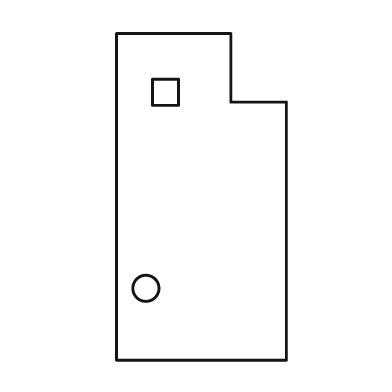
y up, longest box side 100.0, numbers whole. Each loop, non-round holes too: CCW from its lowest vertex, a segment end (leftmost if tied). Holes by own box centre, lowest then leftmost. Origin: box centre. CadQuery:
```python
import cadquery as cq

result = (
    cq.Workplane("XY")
    .moveTo(-26.0, -50.0)
    .lineTo(26.0, -50.0)
    .lineTo(26.0, 29.0)
    .lineTo(9.0, 29.0)
    .lineTo(9.0, 50.0)
    .lineTo(-26.0, 50.0)
    .close()
    .moveTo(-17.0, -28.0)
    .circle(4.0)
    .moveTo(-15.0, 28.0)
    .lineTo(-7.0, 28.0)
    .lineTo(-7.0, 36.0)
    .lineTo(-15.0, 36.0)
    .close()
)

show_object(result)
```